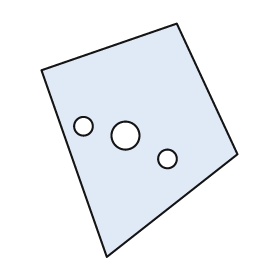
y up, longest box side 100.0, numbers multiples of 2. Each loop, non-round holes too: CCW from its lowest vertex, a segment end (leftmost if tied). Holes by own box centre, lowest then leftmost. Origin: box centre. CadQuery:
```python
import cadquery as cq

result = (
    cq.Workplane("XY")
    .moveTo(-14.0, -50.0)
    .lineTo(42.0, -6.0)
    .lineTo(16.0, 50.0)
    .lineTo(-42.0, 30.0)
    .close()
    .moveTo(12.0, -8.0)
    .circle(4.0)
    .moveTo(-6.0, 2.0)
    .circle(6.0)
    .moveTo(-24.0, 6.0)
    .circle(4.0)
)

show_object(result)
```